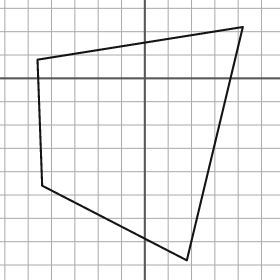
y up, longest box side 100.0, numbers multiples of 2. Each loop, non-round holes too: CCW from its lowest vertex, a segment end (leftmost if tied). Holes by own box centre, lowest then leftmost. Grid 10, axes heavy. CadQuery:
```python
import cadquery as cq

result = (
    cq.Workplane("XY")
    .moveTo(18.0, -78.0)
    .lineTo(42.0, 22.0)
    .lineTo(-46.0, 8.0)
    .lineTo(-44.0, -46.0)
    .close()
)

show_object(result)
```